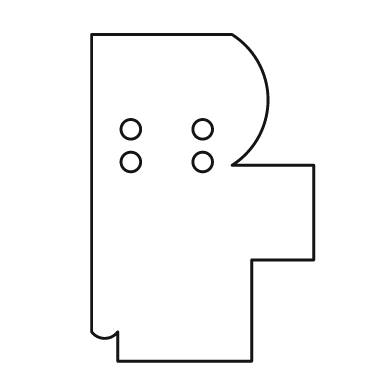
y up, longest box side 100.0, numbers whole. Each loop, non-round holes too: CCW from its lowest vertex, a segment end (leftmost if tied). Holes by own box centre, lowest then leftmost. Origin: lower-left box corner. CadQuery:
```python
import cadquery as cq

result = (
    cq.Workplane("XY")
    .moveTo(8.0, 0.0)
    .lineTo(49.0, 0.0)
    .lineTo(49.0, 31.0)
    .lineTo(68.0, 31.0)
    .lineTo(68.0, 60.0)
    .lineTo(43.0, 60.0)
    .threePointArc((54.0, 80.0), (43.0, 100.0))
    .lineTo(0.0, 100.0)
    .lineTo(0.0, 9.0)
    .threePointArc((4.0, 7.0), (8.0, 9.0))
    .close()
    .moveTo(12.0, 61.0)
    .circle(3.0)
    .moveTo(34.0, 61.0)
    .circle(3.0)
    .moveTo(12.0, 71.0)
    .circle(3.0)
    .moveTo(34.0, 71.0)
    .circle(3.0)
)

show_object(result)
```